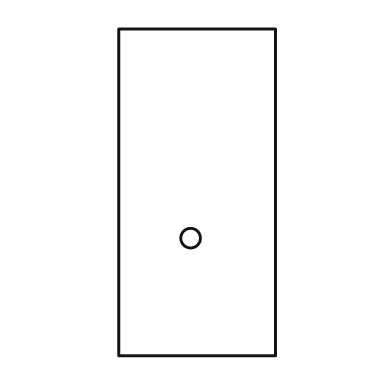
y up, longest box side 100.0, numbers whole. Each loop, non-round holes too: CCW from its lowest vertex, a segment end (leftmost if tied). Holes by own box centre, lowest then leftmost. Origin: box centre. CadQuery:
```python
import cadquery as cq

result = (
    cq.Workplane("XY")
    .moveTo(-24.0, -50.0)
    .lineTo(24.0, -50.0)
    .lineTo(24.0, 50.0)
    .lineTo(-24.0, 50.0)
    .close()
    .moveTo(-2.0, -14.0)
    .circle(3.0)
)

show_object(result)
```